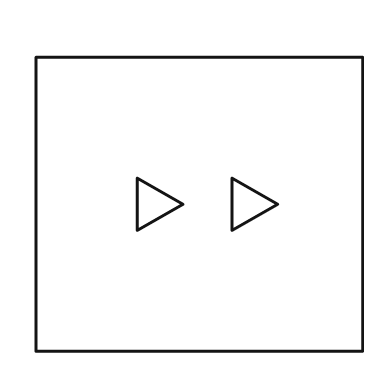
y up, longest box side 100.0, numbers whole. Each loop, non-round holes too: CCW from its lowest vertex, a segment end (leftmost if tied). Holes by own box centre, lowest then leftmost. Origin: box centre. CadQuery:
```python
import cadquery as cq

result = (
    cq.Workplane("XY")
    .moveTo(-50.0, -45.0)
    .lineTo(50.0, -45.0)
    .lineTo(50.0, 45.0)
    .lineTo(-50.0, 45.0)
    .close()
    .moveTo(-19.0, -8.0)
    .lineTo(-5.0, 0.0)
    .lineTo(-19.0, 8.0)
    .close()
    .moveTo(10.0, -8.0)
    .lineTo(24.0, 0.0)
    .lineTo(10.0, 8.0)
    .close()
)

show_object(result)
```